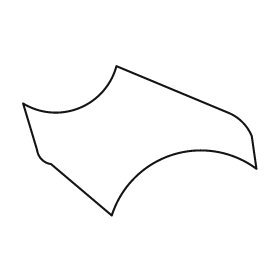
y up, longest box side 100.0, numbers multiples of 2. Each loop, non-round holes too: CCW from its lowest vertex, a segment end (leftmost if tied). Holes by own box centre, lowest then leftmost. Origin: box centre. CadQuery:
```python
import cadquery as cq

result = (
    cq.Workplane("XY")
    .moveTo(-12.0, -32.0)
    .threePointArc((14.0, -6.0), (50.0, -12.0))
    .lineTo(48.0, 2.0)
    .threePointArc((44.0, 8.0), (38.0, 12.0))
    .lineTo(-10.0, 32.0)
    .threePointArc((-26.0, 14.0), (-50.0, 16.0))
    .lineTo(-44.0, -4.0)
    .threePointArc((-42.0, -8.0), (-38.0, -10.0))
    .close()
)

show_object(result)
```